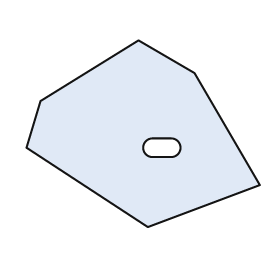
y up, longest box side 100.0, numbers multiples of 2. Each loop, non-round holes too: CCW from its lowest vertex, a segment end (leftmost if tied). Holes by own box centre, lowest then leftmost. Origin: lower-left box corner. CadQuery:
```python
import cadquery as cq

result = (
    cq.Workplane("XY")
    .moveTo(52.0, 0.0)
    .lineTo(100.0, 18.0)
    .lineTo(72.0, 66.0)
    .lineTo(48.0, 80.0)
    .lineTo(6.0, 54.0)
    .lineTo(0.0, 34.0)
    .close()
    .moveTo(54.0, 30.0)
    .lineTo(62.0, 30.0)
    .threePointArc((66.0, 34.0), (62.0, 38.0))
    .lineTo(54.0, 38.0)
    .threePointArc((50.0, 34.0), (54.0, 30.0))
    .close()
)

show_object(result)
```